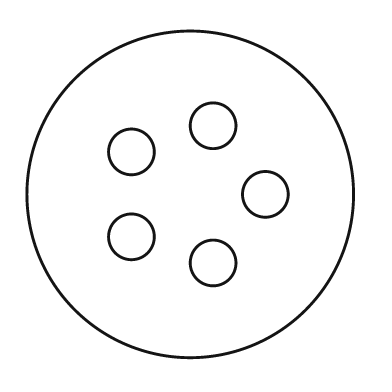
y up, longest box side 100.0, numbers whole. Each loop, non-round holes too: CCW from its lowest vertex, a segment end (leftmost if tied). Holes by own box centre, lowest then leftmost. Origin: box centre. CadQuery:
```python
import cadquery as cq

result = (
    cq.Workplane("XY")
    .moveTo(0.0, 0.0)
    .circle(50.0)
    .moveTo(7.0, -21.0)
    .circle(7.0)
    .moveTo(-18.0, -13.0)
    .circle(7.0)
    .moveTo(23.0, 0.0)
    .circle(7.0)
    .moveTo(-18.0, 13.0)
    .circle(7.0)
    .moveTo(7.0, 21.0)
    .circle(7.0)
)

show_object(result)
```